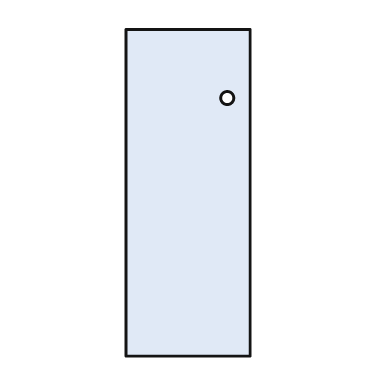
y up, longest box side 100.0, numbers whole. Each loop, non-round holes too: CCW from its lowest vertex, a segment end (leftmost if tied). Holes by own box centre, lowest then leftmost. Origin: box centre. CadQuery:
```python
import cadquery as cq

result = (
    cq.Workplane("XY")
    .moveTo(-19.0, -50.0)
    .lineTo(19.0, -50.0)
    .lineTo(19.0, 50.0)
    .lineTo(-19.0, 50.0)
    .close()
    .moveTo(12.0, 29.0)
    .circle(2.0)
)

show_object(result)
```